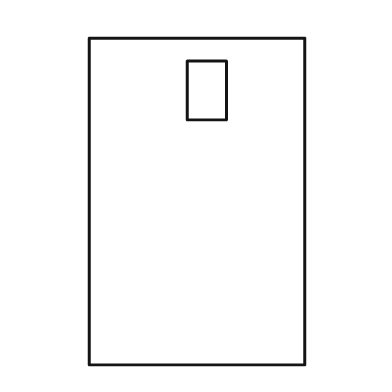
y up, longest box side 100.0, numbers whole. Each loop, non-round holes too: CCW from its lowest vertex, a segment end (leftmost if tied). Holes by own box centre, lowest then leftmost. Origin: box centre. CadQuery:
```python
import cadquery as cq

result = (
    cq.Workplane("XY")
    .moveTo(-33.0, -50.0)
    .lineTo(33.0, -50.0)
    .lineTo(33.0, 50.0)
    .lineTo(-33.0, 50.0)
    .close()
    .moveTo(-3.0, 25.0)
    .lineTo(9.0, 25.0)
    .lineTo(9.0, 43.0)
    .lineTo(-3.0, 43.0)
    .close()
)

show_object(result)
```